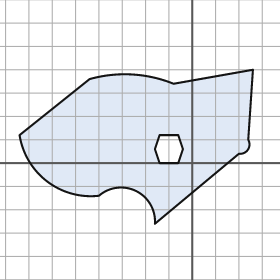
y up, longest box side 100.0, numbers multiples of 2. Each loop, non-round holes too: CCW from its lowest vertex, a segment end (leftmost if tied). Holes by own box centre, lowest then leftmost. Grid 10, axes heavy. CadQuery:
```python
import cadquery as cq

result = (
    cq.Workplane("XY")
    .moveTo(-16.0, -26.0)
    .lineTo(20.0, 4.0)
    .threePointArc((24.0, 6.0), (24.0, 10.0))
    .lineTo(26.0, 40.0)
    .lineTo(-8.0, 34.0)
    .threePointArc((-26.0, 38.0), (-44.0, 36.0))
    .lineTo(-74.0, 12.0)
    .threePointArc((-62.0, -8.0), (-40.0, -14.0))
    .threePointArc((-24.0, -12.0), (-16.0, -26.0))
    .close()
    .moveTo(-14.0, 0.0)
    .lineTo(-6.0, 0.0)
    .lineTo(-4.0, 6.0)
    .lineTo(-6.0, 12.0)
    .lineTo(-14.0, 12.0)
    .lineTo(-16.0, 6.0)
    .close()
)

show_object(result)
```